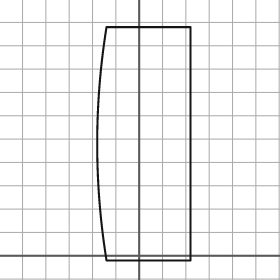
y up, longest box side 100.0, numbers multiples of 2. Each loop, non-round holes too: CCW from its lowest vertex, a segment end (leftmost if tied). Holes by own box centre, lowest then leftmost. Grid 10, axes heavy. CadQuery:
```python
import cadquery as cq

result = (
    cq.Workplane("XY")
    .moveTo(-14.0, -2.0)
    .lineTo(22.0, -2.0)
    .lineTo(22.0, 98.0)
    .lineTo(-14.0, 98.0)
    .threePointArc((-18.0, 48.0), (-14.0, -2.0))
    .close()
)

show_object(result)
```